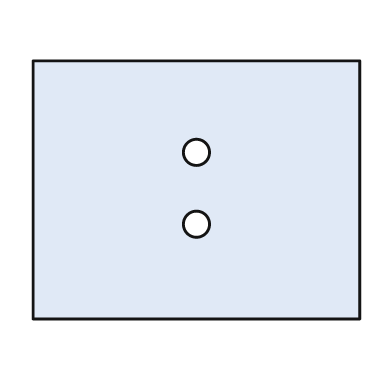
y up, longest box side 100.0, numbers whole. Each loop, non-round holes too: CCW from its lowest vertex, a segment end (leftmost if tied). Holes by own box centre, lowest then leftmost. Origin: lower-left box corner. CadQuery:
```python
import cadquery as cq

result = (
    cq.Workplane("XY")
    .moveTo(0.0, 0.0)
    .lineTo(100.0, 0.0)
    .lineTo(100.0, 79.0)
    .lineTo(0.0, 79.0)
    .close()
    .moveTo(50.0, 29.0)
    .circle(4.0)
    .moveTo(50.0, 51.0)
    .circle(4.0)
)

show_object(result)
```